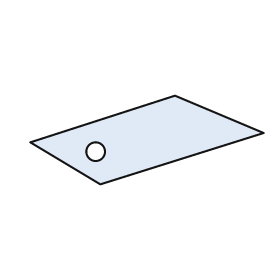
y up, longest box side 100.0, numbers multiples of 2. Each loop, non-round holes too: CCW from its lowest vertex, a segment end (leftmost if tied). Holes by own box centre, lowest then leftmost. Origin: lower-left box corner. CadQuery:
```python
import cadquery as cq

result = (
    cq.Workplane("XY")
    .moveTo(30.0, 0.0)
    .lineTo(100.0, 22.0)
    .lineTo(62.0, 38.0)
    .lineTo(0.0, 18.0)
    .close()
    .moveTo(28.0, 14.0)
    .circle(4.0)
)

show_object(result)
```